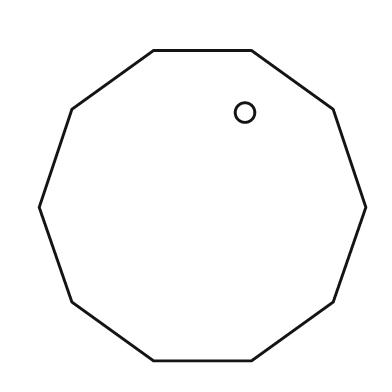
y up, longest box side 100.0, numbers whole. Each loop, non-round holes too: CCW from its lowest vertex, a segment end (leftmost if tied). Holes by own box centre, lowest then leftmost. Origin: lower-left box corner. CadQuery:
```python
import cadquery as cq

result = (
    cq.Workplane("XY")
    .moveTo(35.0, 0.0)
    .lineTo(65.0, 0.0)
    .lineTo(90.0, 18.0)
    .lineTo(100.0, 47.0)
    .lineTo(90.0, 77.0)
    .lineTo(65.0, 95.0)
    .lineTo(35.0, 95.0)
    .lineTo(10.0, 77.0)
    .lineTo(0.0, 47.0)
    .lineTo(10.0, 18.0)
    .close()
    .moveTo(63.0, 76.0)
    .circle(3.0)
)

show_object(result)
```